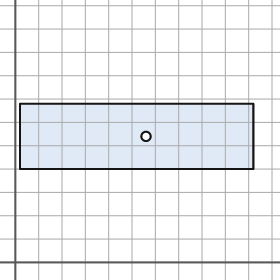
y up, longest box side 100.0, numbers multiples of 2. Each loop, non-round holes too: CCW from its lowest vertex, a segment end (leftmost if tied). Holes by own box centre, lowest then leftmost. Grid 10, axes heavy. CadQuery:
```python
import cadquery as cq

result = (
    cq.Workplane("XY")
    .moveTo(2.0, 40.0)
    .lineTo(102.0, 40.0)
    .lineTo(102.0, 68.0)
    .lineTo(2.0, 68.0)
    .close()
    .moveTo(56.0, 54.0)
    .circle(2.0)
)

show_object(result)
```